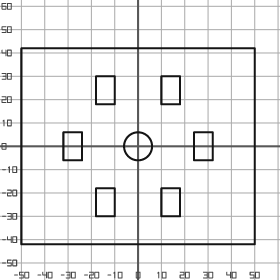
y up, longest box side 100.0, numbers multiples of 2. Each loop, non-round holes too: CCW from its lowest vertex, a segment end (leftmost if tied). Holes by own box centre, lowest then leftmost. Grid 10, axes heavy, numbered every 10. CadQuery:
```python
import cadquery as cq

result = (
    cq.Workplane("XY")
    .moveTo(-50.0, -42.0)
    .lineTo(50.0, -42.0)
    .lineTo(50.0, 42.0)
    .lineTo(-50.0, 42.0)
    .close()
    .moveTo(-18.0, -30.0)
    .lineTo(-10.0, -30.0)
    .lineTo(-10.0, -18.0)
    .lineTo(-18.0, -18.0)
    .close()
    .moveTo(10.0, -30.0)
    .lineTo(18.0, -30.0)
    .lineTo(18.0, -18.0)
    .lineTo(10.0, -18.0)
    .close()
    .moveTo(-32.0, -6.0)
    .lineTo(-24.0, -6.0)
    .lineTo(-24.0, 6.0)
    .lineTo(-32.0, 6.0)
    .close()
    .moveTo(0.0, 0.0)
    .circle(6.0)
    .moveTo(24.0, -6.0)
    .lineTo(32.0, -6.0)
    .lineTo(32.0, 6.0)
    .lineTo(24.0, 6.0)
    .close()
    .moveTo(-18.0, 18.0)
    .lineTo(-10.0, 18.0)
    .lineTo(-10.0, 30.0)
    .lineTo(-18.0, 30.0)
    .close()
    .moveTo(10.0, 18.0)
    .lineTo(18.0, 18.0)
    .lineTo(18.0, 30.0)
    .lineTo(10.0, 30.0)
    .close()
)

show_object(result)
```